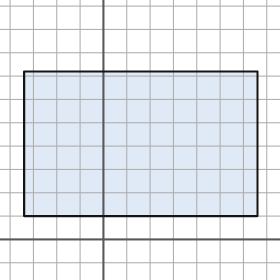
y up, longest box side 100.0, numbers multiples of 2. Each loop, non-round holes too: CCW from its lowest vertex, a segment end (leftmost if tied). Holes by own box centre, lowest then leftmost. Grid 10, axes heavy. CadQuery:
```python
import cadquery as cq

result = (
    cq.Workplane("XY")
    .moveTo(-34.0, 10.0)
    .lineTo(66.0, 10.0)
    .lineTo(66.0, 72.0)
    .lineTo(-34.0, 72.0)
    .close()
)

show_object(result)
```